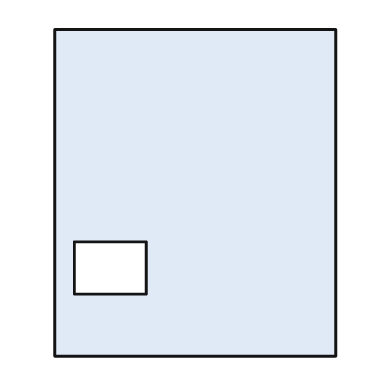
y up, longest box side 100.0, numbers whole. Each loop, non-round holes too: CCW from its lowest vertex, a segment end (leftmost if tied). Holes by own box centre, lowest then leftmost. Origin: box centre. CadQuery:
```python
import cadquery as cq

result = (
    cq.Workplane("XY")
    .moveTo(-43.0, -50.0)
    .lineTo(43.0, -50.0)
    .lineTo(43.0, 50.0)
    .lineTo(-43.0, 50.0)
    .close()
    .moveTo(-37.0, -31.0)
    .lineTo(-15.0, -31.0)
    .lineTo(-15.0, -15.0)
    .lineTo(-37.0, -15.0)
    .close()
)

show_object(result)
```